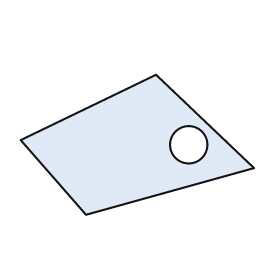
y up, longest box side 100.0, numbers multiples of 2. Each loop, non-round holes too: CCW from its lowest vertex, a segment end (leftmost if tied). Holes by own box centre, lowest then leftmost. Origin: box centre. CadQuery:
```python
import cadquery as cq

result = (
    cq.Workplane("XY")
    .moveTo(-22.0, -30.0)
    .lineTo(50.0, -10.0)
    .lineTo(8.0, 30.0)
    .lineTo(-50.0, 2.0)
    .close()
    .moveTo(22.0, 0.0)
    .circle(8.0)
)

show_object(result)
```